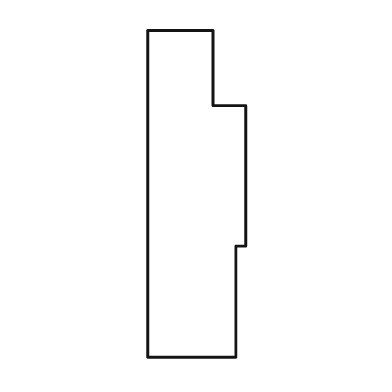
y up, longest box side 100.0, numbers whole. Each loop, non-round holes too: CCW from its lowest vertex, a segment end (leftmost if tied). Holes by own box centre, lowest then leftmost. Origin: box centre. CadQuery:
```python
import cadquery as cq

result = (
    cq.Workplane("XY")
    .moveTo(-15.0, -50.0)
    .lineTo(12.0, -50.0)
    .lineTo(12.0, -16.0)
    .lineTo(15.0, -16.0)
    .lineTo(15.0, 27.0)
    .lineTo(5.0, 27.0)
    .lineTo(5.0, 50.0)
    .lineTo(-15.0, 50.0)
    .close()
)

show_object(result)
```